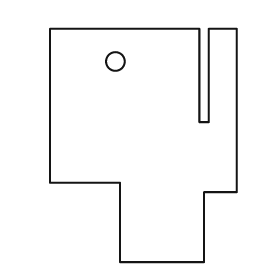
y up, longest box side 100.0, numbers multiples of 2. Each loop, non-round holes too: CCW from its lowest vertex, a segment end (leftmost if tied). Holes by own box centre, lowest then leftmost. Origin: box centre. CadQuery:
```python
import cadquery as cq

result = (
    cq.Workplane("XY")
    .moveTo(-10.0, -50.0)
    .lineTo(26.0, -50.0)
    .lineTo(26.0, -20.0)
    .lineTo(40.0, -20.0)
    .lineTo(40.0, 50.0)
    .lineTo(28.0, 50.0)
    .lineTo(28.0, 10.0)
    .lineTo(24.0, 10.0)
    .lineTo(24.0, 50.0)
    .lineTo(-40.0, 50.0)
    .lineTo(-40.0, -16.0)
    .lineTo(-10.0, -16.0)
    .close()
    .moveTo(-12.0, 36.0)
    .circle(4.0)
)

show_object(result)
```